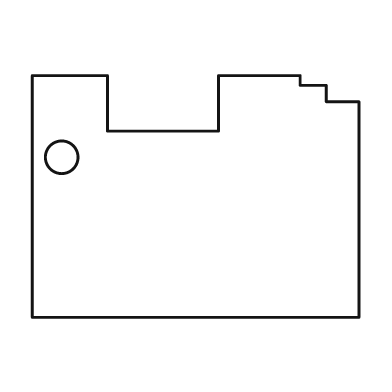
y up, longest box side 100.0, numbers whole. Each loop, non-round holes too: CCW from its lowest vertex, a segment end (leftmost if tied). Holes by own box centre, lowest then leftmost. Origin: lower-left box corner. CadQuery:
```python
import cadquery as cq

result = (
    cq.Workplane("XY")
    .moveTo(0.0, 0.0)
    .lineTo(100.0, 0.0)
    .lineTo(100.0, 66.0)
    .lineTo(90.0, 66.0)
    .lineTo(90.0, 71.0)
    .lineTo(82.0, 71.0)
    .lineTo(82.0, 74.0)
    .lineTo(57.0, 74.0)
    .lineTo(57.0, 57.0)
    .lineTo(23.0, 57.0)
    .lineTo(23.0, 74.0)
    .lineTo(0.0, 74.0)
    .close()
    .moveTo(9.0, 49.0)
    .circle(5.0)
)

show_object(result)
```